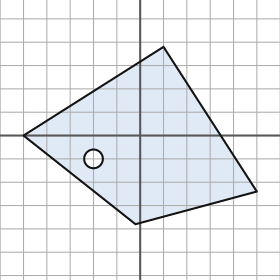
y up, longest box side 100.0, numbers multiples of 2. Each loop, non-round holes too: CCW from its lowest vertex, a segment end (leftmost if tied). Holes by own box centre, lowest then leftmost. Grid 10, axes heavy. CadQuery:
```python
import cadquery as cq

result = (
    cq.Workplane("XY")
    .moveTo(-2.0, -38.0)
    .lineTo(50.0, -24.0)
    .lineTo(10.0, 38.0)
    .lineTo(-50.0, 0.0)
    .close()
    .moveTo(-20.0, -10.0)
    .circle(4.0)
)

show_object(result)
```